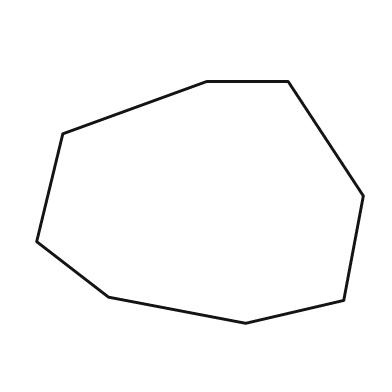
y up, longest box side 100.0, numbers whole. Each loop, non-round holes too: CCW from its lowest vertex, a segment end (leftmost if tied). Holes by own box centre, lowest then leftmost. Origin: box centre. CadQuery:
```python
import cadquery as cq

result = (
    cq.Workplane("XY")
    .moveTo(14.0, -37.0)
    .lineTo(44.0, -30.0)
    .lineTo(50.0, 2.0)
    .lineTo(27.0, 37.0)
    .lineTo(2.0, 37.0)
    .lineTo(-42.0, 21.0)
    .lineTo(-50.0, -12.0)
    .lineTo(-28.0, -29.0)
    .close()
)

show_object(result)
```